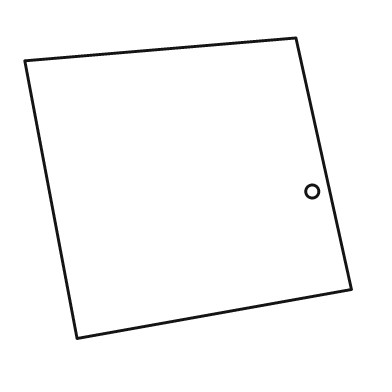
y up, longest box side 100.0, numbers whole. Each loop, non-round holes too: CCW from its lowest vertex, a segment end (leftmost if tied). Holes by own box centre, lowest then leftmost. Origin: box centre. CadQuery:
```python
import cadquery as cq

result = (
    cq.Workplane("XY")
    .moveTo(-34.0, -46.0)
    .lineTo(50.0, -31.0)
    .lineTo(33.0, 46.0)
    .lineTo(-50.0, 39.0)
    .close()
    .moveTo(38.0, -1.0)
    .circle(2.0)
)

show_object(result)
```